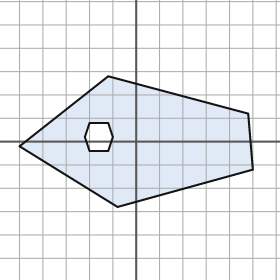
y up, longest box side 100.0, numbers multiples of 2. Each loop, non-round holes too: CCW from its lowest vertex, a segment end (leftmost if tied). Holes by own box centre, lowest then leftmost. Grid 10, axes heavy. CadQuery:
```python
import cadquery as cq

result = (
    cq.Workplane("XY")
    .moveTo(-8.0, -28.0)
    .lineTo(50.0, -12.0)
    .lineTo(48.0, 12.0)
    .lineTo(-12.0, 28.0)
    .lineTo(-50.0, -2.0)
    .close()
    .moveTo(-20.0, -4.0)
    .lineTo(-12.0, -4.0)
    .lineTo(-10.0, 2.0)
    .lineTo(-12.0, 8.0)
    .lineTo(-20.0, 8.0)
    .lineTo(-22.0, 2.0)
    .close()
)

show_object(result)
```